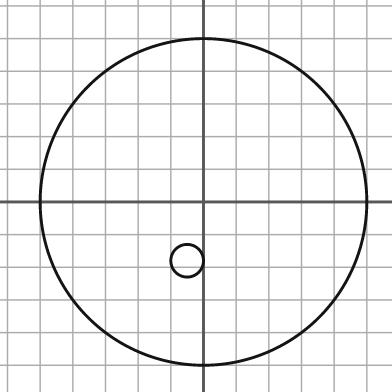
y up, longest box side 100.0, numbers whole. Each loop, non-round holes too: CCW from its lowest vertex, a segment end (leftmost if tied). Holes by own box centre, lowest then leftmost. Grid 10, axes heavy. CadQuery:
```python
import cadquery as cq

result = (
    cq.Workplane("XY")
    .moveTo(0.0, 0.0)
    .circle(50.0)
    .moveTo(-5.0, -18.0)
    .circle(5.0)
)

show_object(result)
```